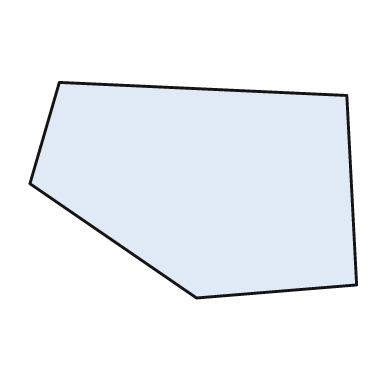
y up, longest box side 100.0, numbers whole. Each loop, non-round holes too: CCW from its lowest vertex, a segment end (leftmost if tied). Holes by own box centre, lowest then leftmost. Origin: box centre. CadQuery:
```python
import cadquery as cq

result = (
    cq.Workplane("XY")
    .moveTo(1.0, -33.0)
    .lineTo(50.0, -29.0)
    .lineTo(47.0, 29.0)
    .lineTo(-41.0, 33.0)
    .lineTo(-50.0, 2.0)
    .close()
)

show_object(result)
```